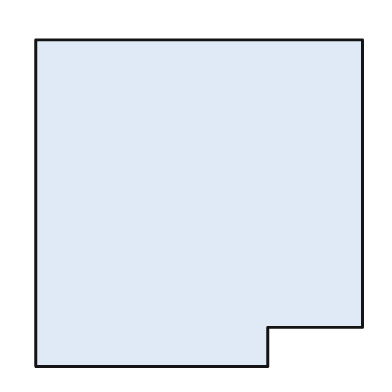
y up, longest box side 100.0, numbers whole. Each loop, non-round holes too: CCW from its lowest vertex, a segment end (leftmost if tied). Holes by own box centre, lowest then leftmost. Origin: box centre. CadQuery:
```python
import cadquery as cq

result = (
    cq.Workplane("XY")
    .moveTo(-50.0, -50.0)
    .lineTo(21.0, -50.0)
    .lineTo(21.0, -38.0)
    .lineTo(50.0, -38.0)
    .lineTo(50.0, 50.0)
    .lineTo(-50.0, 50.0)
    .close()
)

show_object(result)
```